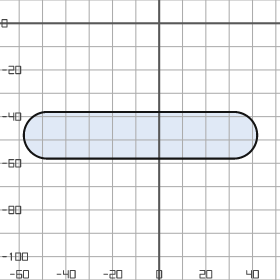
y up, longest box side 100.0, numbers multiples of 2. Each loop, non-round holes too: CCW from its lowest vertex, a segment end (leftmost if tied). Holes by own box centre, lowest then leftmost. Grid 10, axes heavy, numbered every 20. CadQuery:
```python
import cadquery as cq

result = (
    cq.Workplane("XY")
    .moveTo(-48.0, -58.0)
    .lineTo(32.0, -58.0)
    .threePointArc((42.0, -48.0), (32.0, -38.0))
    .lineTo(-48.0, -38.0)
    .threePointArc((-58.0, -48.0), (-48.0, -58.0))
    .close()
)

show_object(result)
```